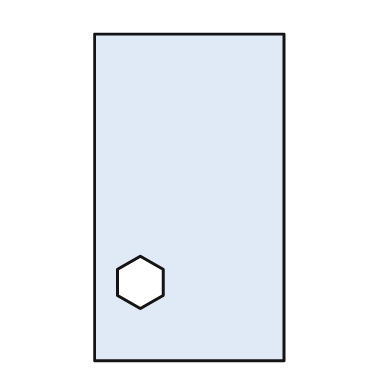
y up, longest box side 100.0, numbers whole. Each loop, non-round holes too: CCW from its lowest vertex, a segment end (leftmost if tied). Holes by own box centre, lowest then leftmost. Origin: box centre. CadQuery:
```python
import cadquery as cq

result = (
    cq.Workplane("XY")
    .moveTo(-29.0, -50.0)
    .lineTo(29.0, -50.0)
    .lineTo(29.0, 50.0)
    .lineTo(-29.0, 50.0)
    .close()
    .moveTo(-15.0, -34.0)
    .lineTo(-8.0, -30.0)
    .lineTo(-8.0, -22.0)
    .lineTo(-15.0, -18.0)
    .lineTo(-22.0, -22.0)
    .lineTo(-22.0, -30.0)
    .close()
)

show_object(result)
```